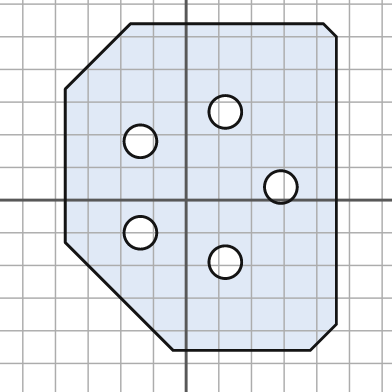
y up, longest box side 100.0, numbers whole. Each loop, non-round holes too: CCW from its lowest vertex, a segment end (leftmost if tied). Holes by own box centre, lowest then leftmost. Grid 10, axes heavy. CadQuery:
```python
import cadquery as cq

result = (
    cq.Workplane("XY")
    .moveTo(-4.0, -46.0)
    .lineTo(38.0, -46.0)
    .lineTo(46.0, -38.0)
    .lineTo(46.0, 50.0)
    .lineTo(42.0, 54.0)
    .lineTo(-17.0, 54.0)
    .lineTo(-37.0, 34.0)
    .lineTo(-37.0, -13.0)
    .close()
    .moveTo(12.0, -19.0)
    .circle(5.0)
    .moveTo(-14.0, -10.0)
    .circle(5.0)
    .moveTo(29.0, 4.0)
    .circle(5.0)
    .moveTo(-14.0, 18.0)
    .circle(5.0)
    .moveTo(12.0, 27.0)
    .circle(5.0)
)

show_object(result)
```